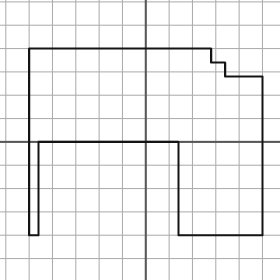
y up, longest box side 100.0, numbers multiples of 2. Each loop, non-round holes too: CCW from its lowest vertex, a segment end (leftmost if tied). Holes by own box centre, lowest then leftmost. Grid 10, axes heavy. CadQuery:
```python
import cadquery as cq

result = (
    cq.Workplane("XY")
    .moveTo(-50.0, -40.0)
    .lineTo(-46.0, -40.0)
    .lineTo(-46.0, 0.0)
    .lineTo(14.0, 0.0)
    .lineTo(14.0, -40.0)
    .lineTo(50.0, -40.0)
    .lineTo(50.0, 28.0)
    .lineTo(34.0, 28.0)
    .lineTo(34.0, 34.0)
    .lineTo(28.0, 34.0)
    .lineTo(28.0, 40.0)
    .lineTo(-50.0, 40.0)
    .close()
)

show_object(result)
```